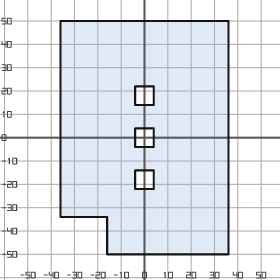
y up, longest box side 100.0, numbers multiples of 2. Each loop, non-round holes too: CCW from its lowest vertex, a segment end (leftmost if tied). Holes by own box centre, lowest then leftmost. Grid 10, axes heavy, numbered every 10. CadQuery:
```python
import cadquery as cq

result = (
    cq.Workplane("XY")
    .moveTo(-16.0, -50.0)
    .lineTo(36.0, -50.0)
    .lineTo(36.0, 50.0)
    .lineTo(-36.0, 50.0)
    .lineTo(-36.0, -34.0)
    .lineTo(-16.0, -34.0)
    .close()
    .moveTo(-4.0, -22.0)
    .lineTo(4.0, -22.0)
    .lineTo(4.0, -14.0)
    .lineTo(-4.0, -14.0)
    .close()
    .moveTo(-4.0, -4.0)
    .lineTo(4.0, -4.0)
    .lineTo(4.0, 4.0)
    .lineTo(-4.0, 4.0)
    .close()
    .moveTo(-4.0, 14.0)
    .lineTo(4.0, 14.0)
    .lineTo(4.0, 22.0)
    .lineTo(-4.0, 22.0)
    .close()
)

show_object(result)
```